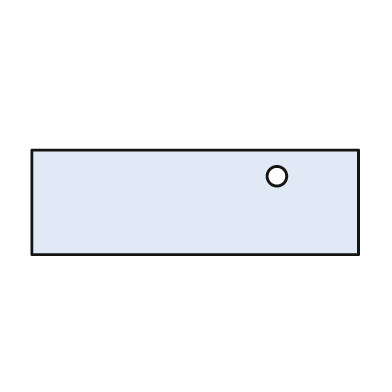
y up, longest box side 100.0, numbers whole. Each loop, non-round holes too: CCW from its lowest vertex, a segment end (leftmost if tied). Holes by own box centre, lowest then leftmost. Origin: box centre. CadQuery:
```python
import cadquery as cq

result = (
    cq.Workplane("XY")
    .moveTo(-50.0, -16.0)
    .lineTo(50.0, -16.0)
    .lineTo(50.0, 16.0)
    .lineTo(-50.0, 16.0)
    .close()
    .moveTo(25.0, 8.0)
    .circle(3.0)
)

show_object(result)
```